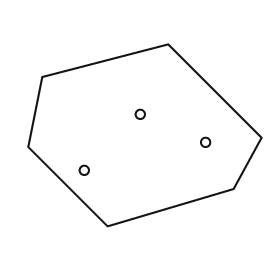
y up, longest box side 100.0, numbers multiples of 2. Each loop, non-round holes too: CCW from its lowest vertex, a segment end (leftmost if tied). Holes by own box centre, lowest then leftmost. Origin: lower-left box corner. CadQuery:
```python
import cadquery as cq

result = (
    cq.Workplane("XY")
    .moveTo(34.0, 0.0)
    .lineTo(88.0, 16.0)
    .lineTo(100.0, 38.0)
    .lineTo(60.0, 78.0)
    .lineTo(6.0, 64.0)
    .lineTo(0.0, 34.0)
    .close()
    .moveTo(24.0, 24.0)
    .circle(2.0)
    .moveTo(76.0, 36.0)
    .circle(2.0)
    .moveTo(48.0, 48.0)
    .circle(2.0)
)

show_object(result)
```